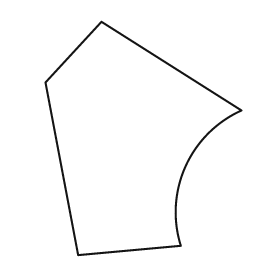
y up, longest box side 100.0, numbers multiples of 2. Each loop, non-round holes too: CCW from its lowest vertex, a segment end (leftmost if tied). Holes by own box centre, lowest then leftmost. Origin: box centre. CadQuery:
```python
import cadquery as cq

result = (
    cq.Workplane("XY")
    .moveTo(-28.0, -50.0)
    .lineTo(16.0, -46.0)
    .threePointArc((18.0, -12.0), (42.0, 12.0))
    .lineTo(-18.0, 50.0)
    .lineTo(-42.0, 24.0)
    .close()
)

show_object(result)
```